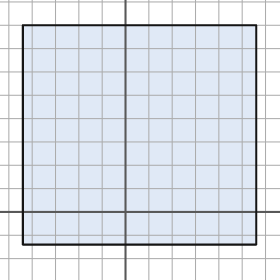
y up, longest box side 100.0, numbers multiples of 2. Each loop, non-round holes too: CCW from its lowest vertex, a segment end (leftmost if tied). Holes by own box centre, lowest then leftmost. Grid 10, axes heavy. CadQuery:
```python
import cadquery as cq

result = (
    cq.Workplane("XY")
    .moveTo(-44.0, -14.0)
    .lineTo(56.0, -14.0)
    .lineTo(56.0, 80.0)
    .lineTo(-44.0, 80.0)
    .close()
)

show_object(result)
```